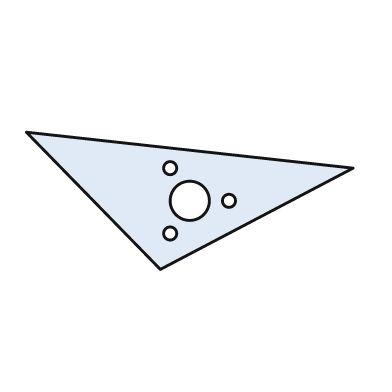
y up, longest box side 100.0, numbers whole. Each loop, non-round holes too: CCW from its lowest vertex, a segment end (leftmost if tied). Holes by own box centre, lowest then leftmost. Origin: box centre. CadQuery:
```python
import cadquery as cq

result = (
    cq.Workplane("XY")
    .moveTo(-9.0, -21.0)
    .lineTo(50.0, 10.0)
    .lineTo(-50.0, 21.0)
    .close()
    .moveTo(-6.0, -10.0)
    .circle(2.0)
    .moveTo(0.0, 0.0)
    .circle(6.0)
    .moveTo(12.0, 0.0)
    .circle(2.0)
    .moveTo(-6.0, 10.0)
    .circle(2.0)
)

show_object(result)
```